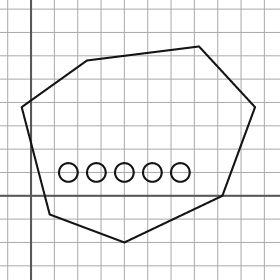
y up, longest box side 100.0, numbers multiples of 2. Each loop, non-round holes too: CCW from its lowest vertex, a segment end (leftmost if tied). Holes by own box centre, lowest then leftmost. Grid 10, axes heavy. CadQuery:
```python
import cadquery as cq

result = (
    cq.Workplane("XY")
    .moveTo(40.0, -20.0)
    .lineTo(82.0, 0.0)
    .lineTo(96.0, 38.0)
    .lineTo(72.0, 64.0)
    .lineTo(24.0, 58.0)
    .lineTo(-4.0, 38.0)
    .lineTo(8.0, -8.0)
    .close()
    .moveTo(16.0, 10.0)
    .circle(4.0)
    .moveTo(28.0, 10.0)
    .circle(4.0)
    .moveTo(40.0, 10.0)
    .circle(4.0)
    .moveTo(52.0, 10.0)
    .circle(4.0)
    .moveTo(64.0, 10.0)
    .circle(4.0)
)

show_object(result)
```